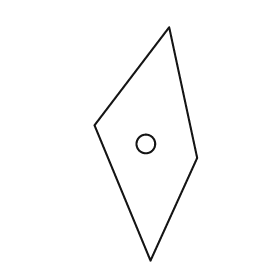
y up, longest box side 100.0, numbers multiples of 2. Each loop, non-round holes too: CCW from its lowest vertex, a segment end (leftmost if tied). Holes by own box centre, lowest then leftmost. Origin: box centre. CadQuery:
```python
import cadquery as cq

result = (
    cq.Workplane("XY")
    .moveTo(2.0, -50.0)
    .lineTo(22.0, -6.0)
    .lineTo(10.0, 50.0)
    .lineTo(-22.0, 8.0)
    .close()
    .moveTo(0.0, 0.0)
    .circle(4.0)
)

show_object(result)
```